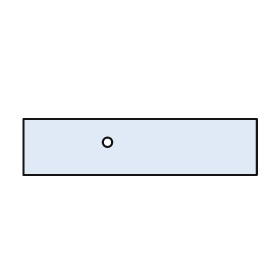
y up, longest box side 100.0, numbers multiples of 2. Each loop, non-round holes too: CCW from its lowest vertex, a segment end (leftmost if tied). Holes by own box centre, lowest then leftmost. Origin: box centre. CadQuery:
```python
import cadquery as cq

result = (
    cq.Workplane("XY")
    .moveTo(-50.0, -12.0)
    .lineTo(50.0, -12.0)
    .lineTo(50.0, 12.0)
    .lineTo(-50.0, 12.0)
    .close()
    .moveTo(-14.0, 2.0)
    .circle(2.0)
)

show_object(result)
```